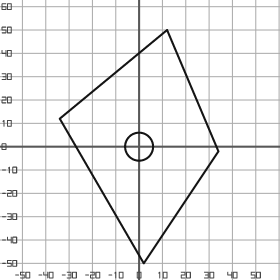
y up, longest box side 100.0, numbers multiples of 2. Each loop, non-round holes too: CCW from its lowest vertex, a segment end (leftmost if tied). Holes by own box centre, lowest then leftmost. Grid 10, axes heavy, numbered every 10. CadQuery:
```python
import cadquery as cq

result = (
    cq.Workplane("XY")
    .moveTo(2.0, -50.0)
    .lineTo(34.0, -2.0)
    .lineTo(12.0, 50.0)
    .lineTo(-34.0, 12.0)
    .close()
    .moveTo(0.0, 0.0)
    .circle(6.0)
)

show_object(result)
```